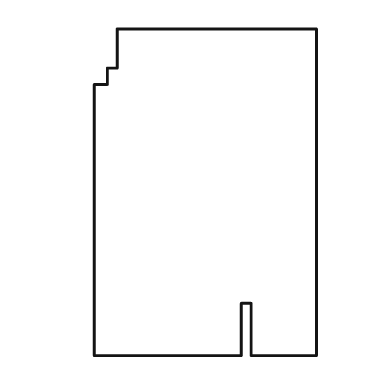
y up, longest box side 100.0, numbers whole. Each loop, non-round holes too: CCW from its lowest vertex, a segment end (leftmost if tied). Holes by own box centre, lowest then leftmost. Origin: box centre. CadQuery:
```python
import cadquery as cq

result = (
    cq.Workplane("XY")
    .moveTo(-34.0, -50.0)
    .lineTo(11.0, -50.0)
    .lineTo(11.0, -34.0)
    .lineTo(14.0, -34.0)
    .lineTo(14.0, -50.0)
    .lineTo(34.0, -50.0)
    .lineTo(34.0, 50.0)
    .lineTo(-27.0, 50.0)
    .lineTo(-27.0, 38.0)
    .lineTo(-30.0, 38.0)
    .lineTo(-30.0, 33.0)
    .lineTo(-34.0, 33.0)
    .close()
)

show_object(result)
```